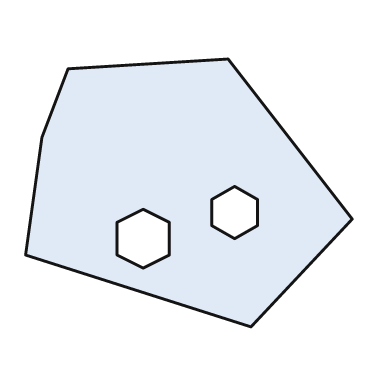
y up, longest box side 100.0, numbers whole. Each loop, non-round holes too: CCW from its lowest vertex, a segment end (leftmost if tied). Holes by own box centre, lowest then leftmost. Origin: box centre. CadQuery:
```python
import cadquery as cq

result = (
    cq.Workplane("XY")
    .moveTo(19.0, -41.0)
    .lineTo(50.0, -8.0)
    .lineTo(12.0, 41.0)
    .lineTo(-37.0, 38.0)
    .lineTo(-45.0, 17.0)
    .lineTo(-50.0, -19.0)
    .close()
    .moveTo(-14.0, -23.0)
    .lineTo(-6.0, -19.0)
    .lineTo(-6.0, -9.0)
    .lineTo(-14.0, -5.0)
    .lineTo(-22.0, -9.0)
    .lineTo(-22.0, -19.0)
    .close()
    .moveTo(14.0, -14.0)
    .lineTo(21.0, -10.0)
    .lineTo(21.0, -2.0)
    .lineTo(14.0, 2.0)
    .lineTo(7.0, -2.0)
    .lineTo(7.0, -10.0)
    .close()
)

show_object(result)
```